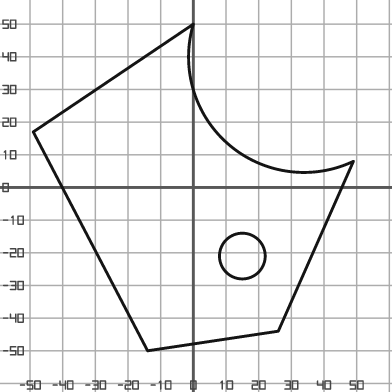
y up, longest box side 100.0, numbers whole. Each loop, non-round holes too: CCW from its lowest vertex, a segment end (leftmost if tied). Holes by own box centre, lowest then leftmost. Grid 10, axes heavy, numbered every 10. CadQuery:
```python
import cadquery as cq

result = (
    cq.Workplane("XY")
    .moveTo(-14.0, -50.0)
    .lineTo(26.0, -44.0)
    .lineTo(49.0, 8.0)
    .threePointArc((11.0, 13.0), (0.0, 50.0))
    .lineTo(-49.0, 17.0)
    .close()
    .moveTo(15.0, -21.0)
    .circle(7.0)
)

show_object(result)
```